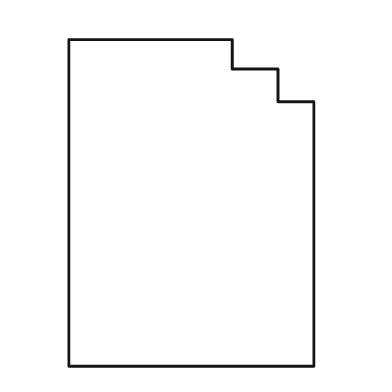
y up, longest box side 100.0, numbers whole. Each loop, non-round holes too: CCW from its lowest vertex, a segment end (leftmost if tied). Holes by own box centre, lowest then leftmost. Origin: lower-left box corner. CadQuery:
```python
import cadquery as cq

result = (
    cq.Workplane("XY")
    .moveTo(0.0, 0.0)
    .lineTo(75.0, 0.0)
    .lineTo(75.0, 81.0)
    .lineTo(64.0, 81.0)
    .lineTo(64.0, 91.0)
    .lineTo(50.0, 91.0)
    .lineTo(50.0, 100.0)
    .lineTo(0.0, 100.0)
    .close()
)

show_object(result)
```